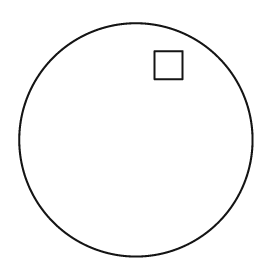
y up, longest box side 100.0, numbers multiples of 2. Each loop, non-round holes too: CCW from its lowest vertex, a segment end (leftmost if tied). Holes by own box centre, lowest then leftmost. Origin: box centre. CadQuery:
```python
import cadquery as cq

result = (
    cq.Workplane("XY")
    .moveTo(0.0, 0.0)
    .circle(50.0)
    .moveTo(8.0, 26.0)
    .lineTo(20.0, 26.0)
    .lineTo(20.0, 38.0)
    .lineTo(8.0, 38.0)
    .close()
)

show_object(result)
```